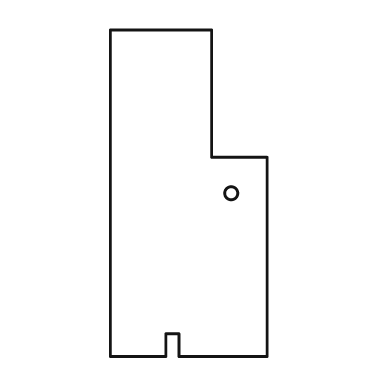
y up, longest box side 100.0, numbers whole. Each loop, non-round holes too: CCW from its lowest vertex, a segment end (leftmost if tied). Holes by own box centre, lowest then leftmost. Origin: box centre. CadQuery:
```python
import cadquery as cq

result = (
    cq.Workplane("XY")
    .moveTo(-24.0, -50.0)
    .lineTo(-7.0, -50.0)
    .lineTo(-7.0, -43.0)
    .lineTo(-3.0, -43.0)
    .lineTo(-3.0, -50.0)
    .lineTo(24.0, -50.0)
    .lineTo(24.0, 11.0)
    .lineTo(7.0, 11.0)
    .lineTo(7.0, 50.0)
    .lineTo(-24.0, 50.0)
    .close()
    .moveTo(13.0, 0.0)
    .circle(2.0)
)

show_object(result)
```